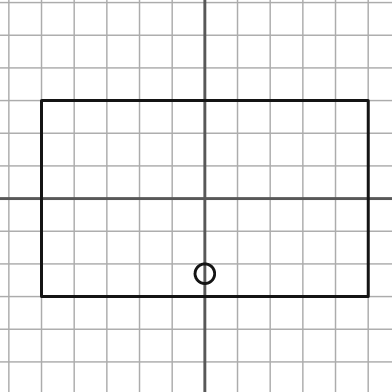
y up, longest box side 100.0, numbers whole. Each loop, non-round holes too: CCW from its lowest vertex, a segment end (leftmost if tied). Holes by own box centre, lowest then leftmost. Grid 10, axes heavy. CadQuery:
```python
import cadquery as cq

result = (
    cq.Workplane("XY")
    .moveTo(-50.0, -30.0)
    .lineTo(50.0, -30.0)
    .lineTo(50.0, 30.0)
    .lineTo(-50.0, 30.0)
    .close()
    .moveTo(0.0, -23.0)
    .circle(3.0)
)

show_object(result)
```